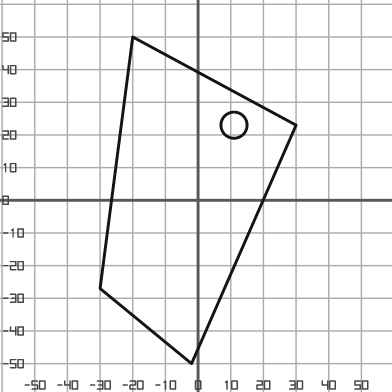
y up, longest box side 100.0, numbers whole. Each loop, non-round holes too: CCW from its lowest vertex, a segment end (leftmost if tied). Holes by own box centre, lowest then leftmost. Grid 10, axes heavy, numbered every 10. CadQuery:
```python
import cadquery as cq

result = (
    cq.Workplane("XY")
    .moveTo(-2.0, -50.0)
    .lineTo(30.0, 23.0)
    .lineTo(-20.0, 50.0)
    .lineTo(-30.0, -27.0)
    .close()
    .moveTo(11.0, 23.0)
    .circle(4.0)
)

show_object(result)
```